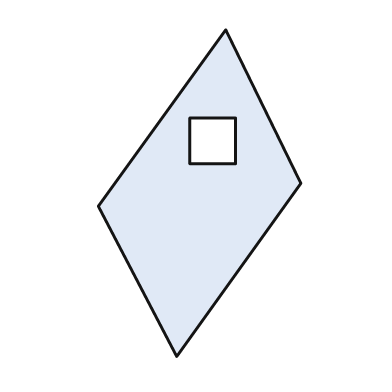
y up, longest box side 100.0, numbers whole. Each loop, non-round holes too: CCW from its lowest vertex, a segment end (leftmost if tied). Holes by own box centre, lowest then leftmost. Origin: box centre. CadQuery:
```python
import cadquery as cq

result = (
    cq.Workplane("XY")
    .moveTo(-7.0, -50.0)
    .lineTo(31.0, 3.0)
    .lineTo(8.0, 50.0)
    .lineTo(-31.0, -4.0)
    .close()
    .moveTo(-3.0, 9.0)
    .lineTo(11.0, 9.0)
    .lineTo(11.0, 23.0)
    .lineTo(-3.0, 23.0)
    .close()
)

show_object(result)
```